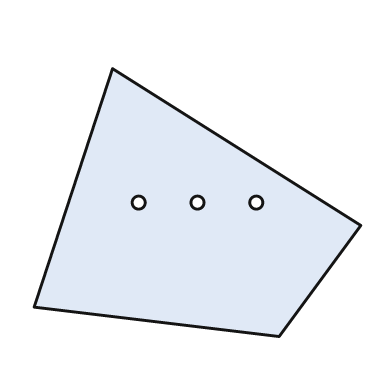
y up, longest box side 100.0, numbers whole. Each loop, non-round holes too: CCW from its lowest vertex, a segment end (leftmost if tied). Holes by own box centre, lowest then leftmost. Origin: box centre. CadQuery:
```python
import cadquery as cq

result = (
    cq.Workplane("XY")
    .moveTo(25.0, -41.0)
    .lineTo(50.0, -7.0)
    .lineTo(-26.0, 41.0)
    .lineTo(-50.0, -32.0)
    .close()
    .moveTo(-18.0, 0.0)
    .circle(2.0)
    .moveTo(0.0, 0.0)
    .circle(2.0)
    .moveTo(18.0, 0.0)
    .circle(2.0)
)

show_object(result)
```